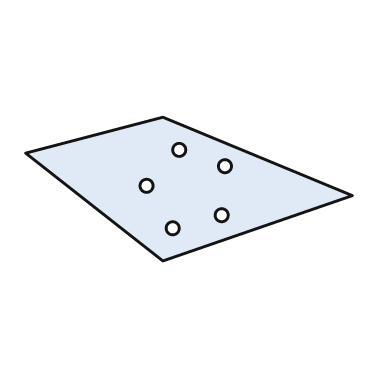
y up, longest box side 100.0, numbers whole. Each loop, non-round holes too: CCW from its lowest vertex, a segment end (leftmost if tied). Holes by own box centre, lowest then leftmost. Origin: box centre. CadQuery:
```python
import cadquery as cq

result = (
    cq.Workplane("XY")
    .moveTo(-8.0, -22.0)
    .lineTo(50.0, -2.0)
    .lineTo(-8.0, 22.0)
    .lineTo(-50.0, 11.0)
    .close()
    .moveTo(-5.0, -12.0)
    .circle(2.0)
    .moveTo(10.0, -8.0)
    .circle(2.0)
    .moveTo(-13.0, 1.0)
    .circle(2.0)
    .moveTo(11.0, 7.0)
    .circle(2.0)
    .moveTo(-3.0, 12.0)
    .circle(2.0)
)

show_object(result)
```